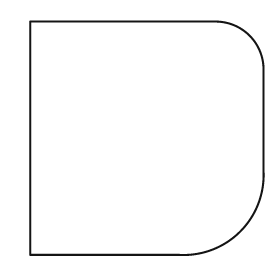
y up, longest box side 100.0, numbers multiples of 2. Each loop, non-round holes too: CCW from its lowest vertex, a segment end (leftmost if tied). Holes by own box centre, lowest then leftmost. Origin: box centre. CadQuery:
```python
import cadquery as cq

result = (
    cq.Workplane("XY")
    .moveTo(-50.0, -50.0)
    .lineTo(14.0, -50.0)
    .threePointArc((40.0, -40.0), (50.0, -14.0))
    .lineTo(50.0, 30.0)
    .threePointArc((44.0, 44.0), (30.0, 50.0))
    .lineTo(-50.0, 50.0)
    .close()
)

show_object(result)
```